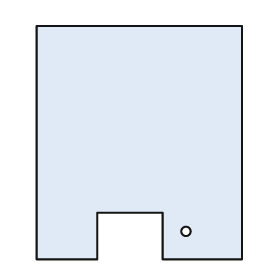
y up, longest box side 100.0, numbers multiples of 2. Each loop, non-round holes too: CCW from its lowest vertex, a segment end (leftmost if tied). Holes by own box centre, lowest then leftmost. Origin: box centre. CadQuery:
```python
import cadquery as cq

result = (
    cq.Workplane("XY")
    .moveTo(-44.0, -50.0)
    .lineTo(-18.0, -50.0)
    .lineTo(-18.0, -30.0)
    .lineTo(10.0, -30.0)
    .lineTo(10.0, -50.0)
    .lineTo(44.0, -50.0)
    .lineTo(44.0, 50.0)
    .lineTo(-44.0, 50.0)
    .close()
    .moveTo(20.0, -38.0)
    .circle(2.0)
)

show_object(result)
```